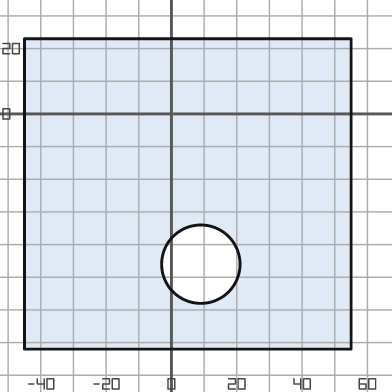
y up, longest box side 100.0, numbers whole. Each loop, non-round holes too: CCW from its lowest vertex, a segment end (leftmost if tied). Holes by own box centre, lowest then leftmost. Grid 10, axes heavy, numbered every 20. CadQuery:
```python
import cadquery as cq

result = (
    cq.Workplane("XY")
    .moveTo(-45.0, -72.0)
    .lineTo(55.0, -72.0)
    .lineTo(55.0, 23.0)
    .lineTo(-45.0, 23.0)
    .close()
    .moveTo(9.0, -46.0)
    .circle(12.0)
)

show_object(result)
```